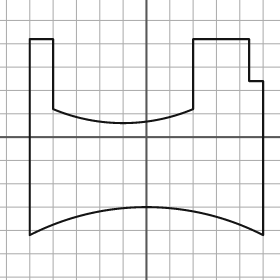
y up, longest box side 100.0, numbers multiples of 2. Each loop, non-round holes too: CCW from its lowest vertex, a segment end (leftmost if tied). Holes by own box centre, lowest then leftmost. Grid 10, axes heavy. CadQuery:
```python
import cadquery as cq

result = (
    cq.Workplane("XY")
    .moveTo(-50.0, -42.0)
    .threePointArc((0.0, -30.0), (50.0, -42.0))
    .lineTo(50.0, 24.0)
    .lineTo(44.0, 24.0)
    .lineTo(44.0, 42.0)
    .lineTo(20.0, 42.0)
    .lineTo(20.0, 12.0)
    .threePointArc((-10.0, 6.0), (-40.0, 12.0))
    .lineTo(-40.0, 42.0)
    .lineTo(-50.0, 42.0)
    .close()
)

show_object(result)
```